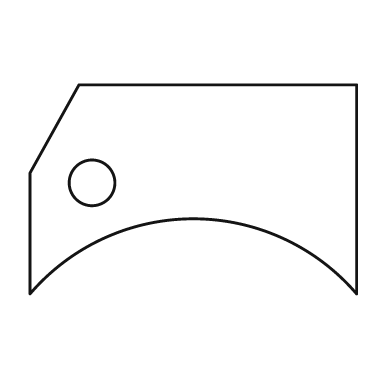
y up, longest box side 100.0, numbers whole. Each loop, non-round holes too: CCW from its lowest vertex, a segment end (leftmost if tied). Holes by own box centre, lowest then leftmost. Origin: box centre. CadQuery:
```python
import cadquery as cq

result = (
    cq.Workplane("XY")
    .moveTo(-50.0, -32.0)
    .threePointArc((0.0, -9.0), (50.0, -32.0))
    .lineTo(50.0, 32.0)
    .lineTo(-35.0, 32.0)
    .lineTo(-50.0, 5.0)
    .close()
    .moveTo(-31.0, 2.0)
    .circle(7.0)
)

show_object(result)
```